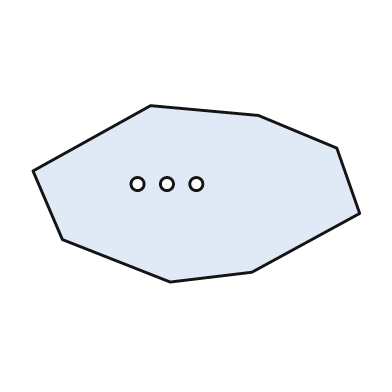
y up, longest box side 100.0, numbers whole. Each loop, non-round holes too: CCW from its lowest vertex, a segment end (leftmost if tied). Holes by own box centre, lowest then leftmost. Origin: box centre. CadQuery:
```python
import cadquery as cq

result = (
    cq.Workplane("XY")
    .moveTo(-8.0, -27.0)
    .lineTo(17.0, -24.0)
    .lineTo(50.0, -6.0)
    .lineTo(43.0, 14.0)
    .lineTo(19.0, 24.0)
    .lineTo(-14.0, 27.0)
    .lineTo(-50.0, 7.0)
    .lineTo(-41.0, -14.0)
    .close()
    .moveTo(-18.0, 3.0)
    .circle(2.0)
    .moveTo(-9.0, 3.0)
    .circle(2.0)
    .moveTo(0.0, 3.0)
    .circle(2.0)
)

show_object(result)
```